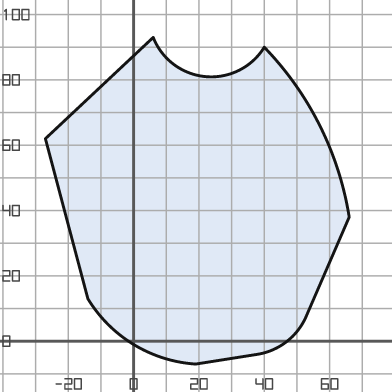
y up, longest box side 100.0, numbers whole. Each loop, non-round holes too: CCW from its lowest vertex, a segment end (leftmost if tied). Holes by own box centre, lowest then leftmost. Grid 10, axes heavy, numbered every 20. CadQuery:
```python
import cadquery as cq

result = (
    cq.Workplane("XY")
    .moveTo(19.0, -7.0)
    .lineTo(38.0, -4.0)
    .threePointArc((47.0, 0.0), (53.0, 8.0))
    .lineTo(66.0, 38.0)
    .threePointArc((57.0, 66.0), (40.0, 90.0))
    .threePointArc((22.0, 81.0), (6.0, 93.0))
    .lineTo(-27.0, 62.0)
    .lineTo(-14.0, 13.0)
    .threePointArc((0.0, -1.0), (19.0, -7.0))
    .close()
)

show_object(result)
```